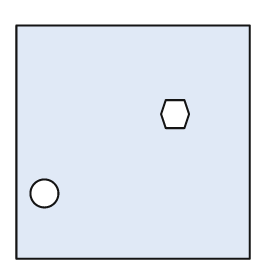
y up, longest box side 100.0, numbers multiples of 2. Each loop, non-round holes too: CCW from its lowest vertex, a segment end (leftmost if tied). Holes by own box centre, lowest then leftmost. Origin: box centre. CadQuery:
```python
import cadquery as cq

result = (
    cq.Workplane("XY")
    .moveTo(-50.0, -50.0)
    .lineTo(50.0, -50.0)
    .lineTo(50.0, 50.0)
    .lineTo(-50.0, 50.0)
    .close()
    .moveTo(-38.0, -22.0)
    .circle(6.0)
    .moveTo(14.0, 6.0)
    .lineTo(22.0, 6.0)
    .lineTo(24.0, 12.0)
    .lineTo(22.0, 18.0)
    .lineTo(14.0, 18.0)
    .lineTo(12.0, 12.0)
    .close()
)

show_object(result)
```